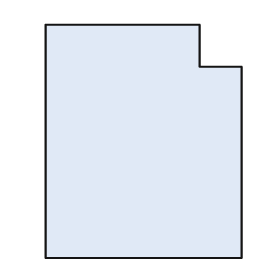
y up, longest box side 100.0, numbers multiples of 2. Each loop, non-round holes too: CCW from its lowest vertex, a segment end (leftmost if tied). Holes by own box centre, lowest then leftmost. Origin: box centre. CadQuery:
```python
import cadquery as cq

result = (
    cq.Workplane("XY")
    .moveTo(-42.0, -50.0)
    .lineTo(42.0, -50.0)
    .lineTo(42.0, 32.0)
    .lineTo(24.0, 32.0)
    .lineTo(24.0, 50.0)
    .lineTo(-42.0, 50.0)
    .close()
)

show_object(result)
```